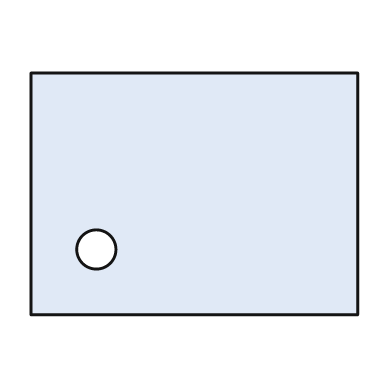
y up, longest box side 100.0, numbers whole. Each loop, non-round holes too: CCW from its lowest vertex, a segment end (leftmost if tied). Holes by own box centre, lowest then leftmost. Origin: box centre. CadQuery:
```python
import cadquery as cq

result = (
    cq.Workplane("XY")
    .moveTo(-50.0, -37.0)
    .lineTo(50.0, -37.0)
    .lineTo(50.0, 37.0)
    .lineTo(-50.0, 37.0)
    .close()
    .moveTo(-30.0, -17.0)
    .circle(6.0)
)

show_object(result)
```